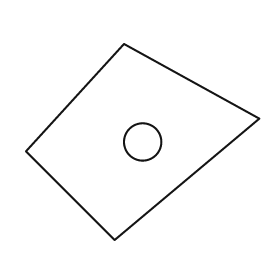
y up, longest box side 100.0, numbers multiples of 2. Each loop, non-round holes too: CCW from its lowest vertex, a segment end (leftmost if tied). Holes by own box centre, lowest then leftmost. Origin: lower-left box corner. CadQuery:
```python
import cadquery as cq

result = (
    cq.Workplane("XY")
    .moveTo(38.0, 0.0)
    .lineTo(100.0, 52.0)
    .lineTo(42.0, 84.0)
    .lineTo(0.0, 38.0)
    .close()
    .moveTo(50.0, 42.0)
    .circle(8.0)
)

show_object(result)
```